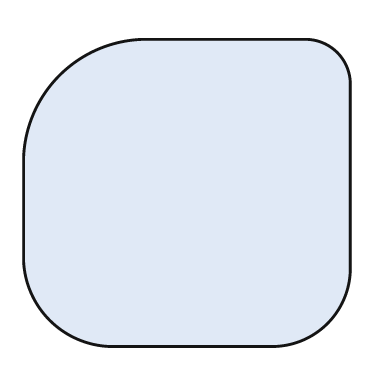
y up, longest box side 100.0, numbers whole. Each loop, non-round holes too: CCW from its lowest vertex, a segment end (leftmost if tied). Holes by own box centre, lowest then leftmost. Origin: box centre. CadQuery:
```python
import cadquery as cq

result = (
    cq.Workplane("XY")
    .moveTo(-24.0, -47.0)
    .lineTo(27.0, -47.0)
    .threePointArc((43.0, -40.0), (50.0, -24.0))
    .lineTo(50.0, 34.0)
    .threePointArc((46.0, 43.0), (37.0, 47.0))
    .lineTo(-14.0, 47.0)
    .threePointArc((-39.0, 36.0), (-50.0, 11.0))
    .lineTo(-50.0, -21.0)
    .threePointArc((-42.0, -39.0), (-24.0, -47.0))
    .close()
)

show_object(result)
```